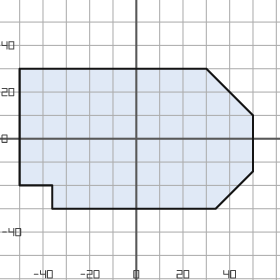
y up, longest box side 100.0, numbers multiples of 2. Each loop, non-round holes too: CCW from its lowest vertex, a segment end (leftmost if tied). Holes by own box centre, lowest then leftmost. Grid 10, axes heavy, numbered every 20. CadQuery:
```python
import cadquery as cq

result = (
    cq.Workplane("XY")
    .moveTo(-36.0, -30.0)
    .lineTo(34.0, -30.0)
    .lineTo(50.0, -14.0)
    .lineTo(50.0, 10.0)
    .lineTo(30.0, 30.0)
    .lineTo(-50.0, 30.0)
    .lineTo(-50.0, -20.0)
    .lineTo(-36.0, -20.0)
    .close()
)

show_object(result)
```